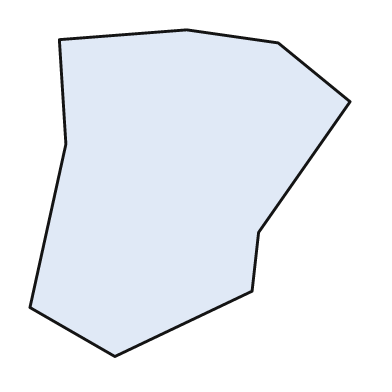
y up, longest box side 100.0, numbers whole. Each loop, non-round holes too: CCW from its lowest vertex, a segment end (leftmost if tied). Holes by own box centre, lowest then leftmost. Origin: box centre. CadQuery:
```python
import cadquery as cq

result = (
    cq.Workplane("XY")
    .moveTo(-23.0, -50.0)
    .lineTo(19.0, -30.0)
    .lineTo(21.0, -12.0)
    .lineTo(49.0, 28.0)
    .lineTo(27.0, 46.0)
    .lineTo(-1.0, 50.0)
    .lineTo(-40.0, 47.0)
    .lineTo(-38.0, 15.0)
    .lineTo(-49.0, -35.0)
    .close()
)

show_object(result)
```